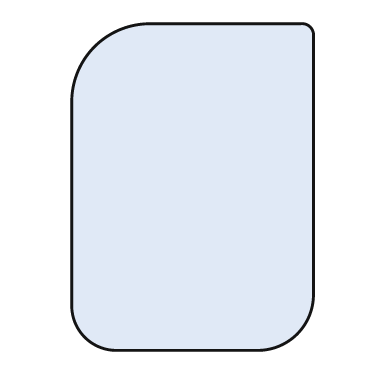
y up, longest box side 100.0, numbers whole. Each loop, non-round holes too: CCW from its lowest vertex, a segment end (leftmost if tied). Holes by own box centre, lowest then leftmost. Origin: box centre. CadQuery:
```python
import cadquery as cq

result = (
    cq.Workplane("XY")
    .moveTo(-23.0, -50.0)
    .lineTo(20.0, -50.0)
    .threePointArc((32.0, -45.0), (37.0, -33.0))
    .lineTo(37.0, 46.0)
    .threePointArc((36.0, 49.0), (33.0, 50.0))
    .lineTo(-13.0, 50.0)
    .threePointArc((-30.0, 43.0), (-37.0, 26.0))
    .lineTo(-37.0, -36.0)
    .threePointArc((-33.0, -46.0), (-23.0, -50.0))
    .close()
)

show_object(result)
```